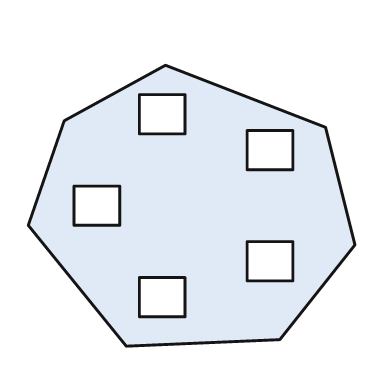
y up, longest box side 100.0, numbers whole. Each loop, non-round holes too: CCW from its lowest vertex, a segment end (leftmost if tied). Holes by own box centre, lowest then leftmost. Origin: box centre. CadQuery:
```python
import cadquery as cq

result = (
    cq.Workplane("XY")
    .moveTo(-20.0, -43.0)
    .lineTo(27.0, -41.0)
    .lineTo(50.0, -12.0)
    .lineTo(41.0, 24.0)
    .lineTo(-8.0, 43.0)
    .lineTo(-39.0, 26.0)
    .lineTo(-50.0, -6.0)
    .close()
    .moveTo(-16.0, -34.0)
    .lineTo(-2.0, -34.0)
    .lineTo(-2.0, -22.0)
    .lineTo(-16.0, -22.0)
    .close()
    .moveTo(17.0, -23.0)
    .lineTo(31.0, -23.0)
    .lineTo(31.0, -11.0)
    .lineTo(17.0, -11.0)
    .close()
    .moveTo(-36.0, -6.0)
    .lineTo(-22.0, -6.0)
    .lineTo(-22.0, 6.0)
    .lineTo(-36.0, 6.0)
    .close()
    .moveTo(17.0, 11.0)
    .lineTo(31.0, 11.0)
    .lineTo(31.0, 23.0)
    .lineTo(17.0, 23.0)
    .close()
    .moveTo(-16.0, 22.0)
    .lineTo(-2.0, 22.0)
    .lineTo(-2.0, 34.0)
    .lineTo(-16.0, 34.0)
    .close()
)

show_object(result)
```